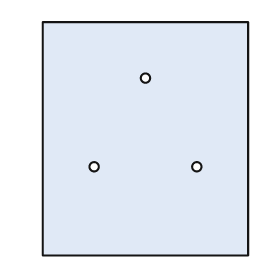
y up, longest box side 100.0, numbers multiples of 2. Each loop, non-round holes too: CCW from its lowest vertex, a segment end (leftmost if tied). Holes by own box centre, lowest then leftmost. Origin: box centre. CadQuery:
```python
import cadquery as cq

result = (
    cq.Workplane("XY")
    .moveTo(-44.0, -50.0)
    .lineTo(44.0, -50.0)
    .lineTo(44.0, 50.0)
    .lineTo(-44.0, 50.0)
    .close()
    .moveTo(-22.0, -12.0)
    .circle(2.0)
    .moveTo(22.0, -12.0)
    .circle(2.0)
    .moveTo(0.0, 26.0)
    .circle(2.0)
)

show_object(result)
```